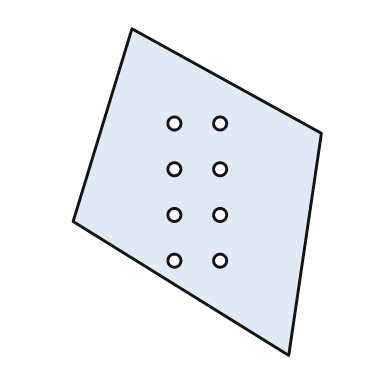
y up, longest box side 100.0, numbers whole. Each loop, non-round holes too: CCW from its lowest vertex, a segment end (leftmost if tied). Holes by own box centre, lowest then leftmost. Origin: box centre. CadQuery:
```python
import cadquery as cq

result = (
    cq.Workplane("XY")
    .moveTo(28.0, -50.0)
    .lineTo(38.0, 18.0)
    .lineTo(-20.0, 50.0)
    .lineTo(-38.0, -9.0)
    .close()
    .moveTo(-7.0, -21.0)
    .circle(2.0)
    .moveTo(7.0, -21.0)
    .circle(2.0)
    .moveTo(-7.0, -7.0)
    .circle(2.0)
    .moveTo(7.0, -7.0)
    .circle(2.0)
    .moveTo(-7.0, 7.0)
    .circle(2.0)
    .moveTo(7.0, 7.0)
    .circle(2.0)
    .moveTo(-7.0, 21.0)
    .circle(2.0)
    .moveTo(7.0, 21.0)
    .circle(2.0)
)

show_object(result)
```